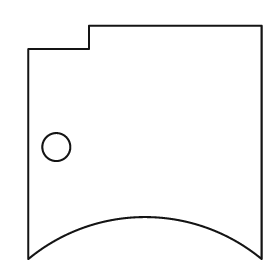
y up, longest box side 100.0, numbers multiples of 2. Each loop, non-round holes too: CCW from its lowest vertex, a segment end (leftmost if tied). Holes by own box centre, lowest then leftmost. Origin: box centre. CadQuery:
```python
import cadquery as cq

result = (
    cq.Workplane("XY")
    .moveTo(-50.0, -50.0)
    .threePointArc((0.0, -32.0), (50.0, -50.0))
    .lineTo(50.0, 50.0)
    .lineTo(-24.0, 50.0)
    .lineTo(-24.0, 40.0)
    .lineTo(-50.0, 40.0)
    .close()
    .moveTo(-38.0, -2.0)
    .circle(6.0)
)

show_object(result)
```